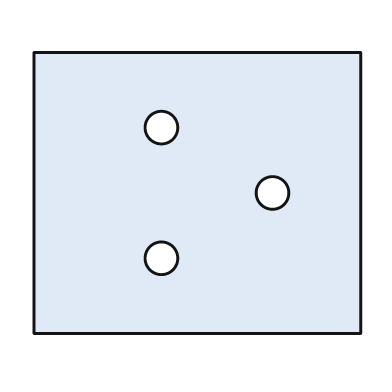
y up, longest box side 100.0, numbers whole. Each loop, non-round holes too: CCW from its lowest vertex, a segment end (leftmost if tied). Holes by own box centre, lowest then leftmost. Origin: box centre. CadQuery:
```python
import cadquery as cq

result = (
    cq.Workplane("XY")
    .moveTo(-50.0, -43.0)
    .lineTo(50.0, -43.0)
    .lineTo(50.0, 43.0)
    .lineTo(-50.0, 43.0)
    .close()
    .moveTo(-11.0, -20.0)
    .circle(5.0)
    .moveTo(23.0, 0.0)
    .circle(5.0)
    .moveTo(-11.0, 20.0)
    .circle(5.0)
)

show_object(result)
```